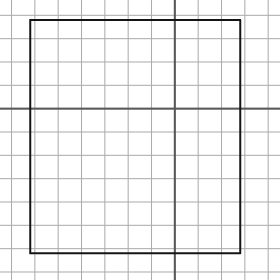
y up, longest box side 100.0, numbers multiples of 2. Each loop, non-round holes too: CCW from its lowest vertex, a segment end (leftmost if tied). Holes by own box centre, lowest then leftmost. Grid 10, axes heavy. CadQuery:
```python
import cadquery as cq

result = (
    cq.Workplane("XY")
    .moveTo(-62.0, -62.0)
    .lineTo(28.0, -62.0)
    .lineTo(28.0, 38.0)
    .lineTo(-62.0, 38.0)
    .close()
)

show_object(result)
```